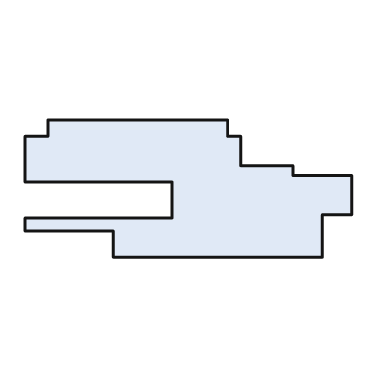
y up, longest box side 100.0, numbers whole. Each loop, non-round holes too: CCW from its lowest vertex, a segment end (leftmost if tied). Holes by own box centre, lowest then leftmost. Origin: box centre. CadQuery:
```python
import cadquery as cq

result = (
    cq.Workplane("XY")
    .moveTo(-23.0, -21.0)
    .lineTo(41.0, -21.0)
    .lineTo(41.0, -8.0)
    .lineTo(50.0, -8.0)
    .lineTo(50.0, 4.0)
    .lineTo(32.0, 4.0)
    .lineTo(32.0, 7.0)
    .lineTo(16.0, 7.0)
    .lineTo(16.0, 16.0)
    .lineTo(12.0, 16.0)
    .lineTo(12.0, 21.0)
    .lineTo(-43.0, 21.0)
    .lineTo(-43.0, 16.0)
    .lineTo(-50.0, 16.0)
    .lineTo(-50.0, 2.0)
    .lineTo(-5.0, 2.0)
    .lineTo(-5.0, -9.0)
    .lineTo(-50.0, -9.0)
    .lineTo(-50.0, -13.0)
    .lineTo(-23.0, -13.0)
    .close()
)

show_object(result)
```